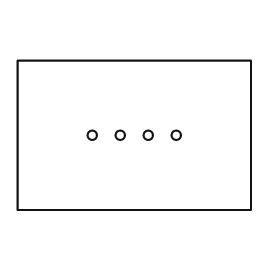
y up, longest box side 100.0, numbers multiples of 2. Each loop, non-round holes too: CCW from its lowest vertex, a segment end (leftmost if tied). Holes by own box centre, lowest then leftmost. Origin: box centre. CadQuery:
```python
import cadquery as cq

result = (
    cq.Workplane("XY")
    .moveTo(-50.0, -32.0)
    .lineTo(50.0, -32.0)
    .lineTo(50.0, 32.0)
    .lineTo(-50.0, 32.0)
    .close()
    .moveTo(-18.0, 0.0)
    .circle(2.0)
    .moveTo(-6.0, 0.0)
    .circle(2.0)
    .moveTo(6.0, 0.0)
    .circle(2.0)
    .moveTo(18.0, 0.0)
    .circle(2.0)
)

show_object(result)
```